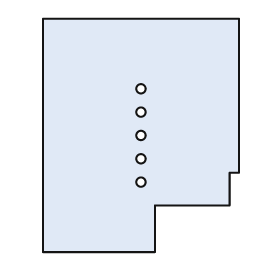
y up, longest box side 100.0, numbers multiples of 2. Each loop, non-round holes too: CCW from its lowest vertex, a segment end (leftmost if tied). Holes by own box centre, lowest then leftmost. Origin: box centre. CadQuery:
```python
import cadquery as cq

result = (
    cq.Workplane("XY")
    .moveTo(-42.0, -50.0)
    .lineTo(6.0, -50.0)
    .lineTo(6.0, -30.0)
    .lineTo(38.0, -30.0)
    .lineTo(38.0, -16.0)
    .lineTo(42.0, -16.0)
    .lineTo(42.0, 50.0)
    .lineTo(-42.0, 50.0)
    .close()
    .moveTo(0.0, -20.0)
    .circle(2.0)
    .moveTo(0.0, -10.0)
    .circle(2.0)
    .moveTo(0.0, 0.0)
    .circle(2.0)
    .moveTo(0.0, 10.0)
    .circle(2.0)
    .moveTo(0.0, 20.0)
    .circle(2.0)
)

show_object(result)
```